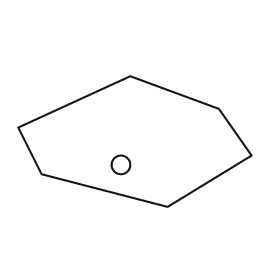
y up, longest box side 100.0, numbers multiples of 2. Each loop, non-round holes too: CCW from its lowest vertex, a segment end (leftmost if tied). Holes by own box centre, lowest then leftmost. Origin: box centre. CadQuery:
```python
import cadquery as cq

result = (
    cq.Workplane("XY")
    .moveTo(14.0, -28.0)
    .lineTo(50.0, -6.0)
    .lineTo(36.0, 14.0)
    .lineTo(-2.0, 28.0)
    .lineTo(-50.0, 6.0)
    .lineTo(-40.0, -14.0)
    .close()
    .moveTo(-6.0, -10.0)
    .circle(4.0)
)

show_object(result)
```